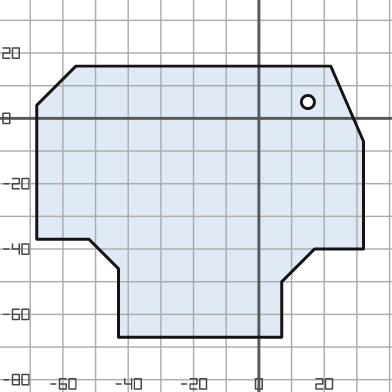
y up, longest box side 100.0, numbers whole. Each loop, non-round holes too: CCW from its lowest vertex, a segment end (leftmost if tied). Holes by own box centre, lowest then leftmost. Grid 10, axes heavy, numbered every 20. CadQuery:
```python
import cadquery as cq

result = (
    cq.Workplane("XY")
    .moveTo(-43.0, -67.0)
    .lineTo(7.0, -67.0)
    .lineTo(7.0, -50.0)
    .lineTo(17.0, -40.0)
    .lineTo(32.0, -40.0)
    .lineTo(32.0, -7.0)
    .lineTo(22.0, 16.0)
    .lineTo(-56.0, 16.0)
    .lineTo(-68.0, 4.0)
    .lineTo(-68.0, -37.0)
    .lineTo(-52.0, -37.0)
    .lineTo(-43.0, -46.0)
    .close()
    .moveTo(15.0, 5.0)
    .circle(2.0)
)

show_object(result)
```